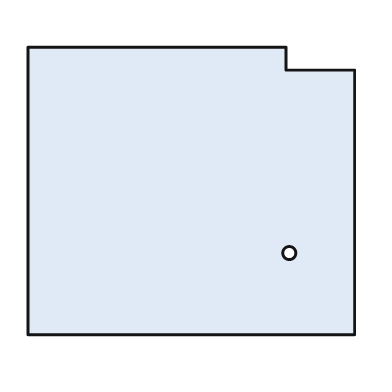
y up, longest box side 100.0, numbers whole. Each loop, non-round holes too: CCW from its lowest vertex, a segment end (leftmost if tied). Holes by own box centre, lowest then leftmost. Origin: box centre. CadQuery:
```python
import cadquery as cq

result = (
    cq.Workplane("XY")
    .moveTo(-50.0, -44.0)
    .lineTo(50.0, -44.0)
    .lineTo(50.0, 37.0)
    .lineTo(29.0, 37.0)
    .lineTo(29.0, 44.0)
    .lineTo(-50.0, 44.0)
    .close()
    .moveTo(30.0, -19.0)
    .circle(2.0)
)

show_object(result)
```